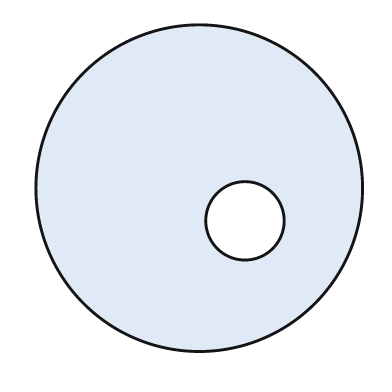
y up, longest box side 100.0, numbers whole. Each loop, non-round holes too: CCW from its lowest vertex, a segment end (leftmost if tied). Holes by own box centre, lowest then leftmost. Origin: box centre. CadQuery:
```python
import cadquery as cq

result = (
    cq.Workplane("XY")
    .moveTo(0.0, 0.0)
    .circle(50.0)
    .moveTo(14.0, -10.0)
    .circle(12.0)
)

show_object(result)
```